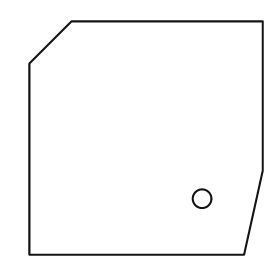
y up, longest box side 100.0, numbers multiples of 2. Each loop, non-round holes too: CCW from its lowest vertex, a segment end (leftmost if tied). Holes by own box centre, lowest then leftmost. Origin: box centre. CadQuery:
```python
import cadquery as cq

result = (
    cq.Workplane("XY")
    .moveTo(-50.0, -50.0)
    .lineTo(42.0, -50.0)
    .lineTo(50.0, -14.0)
    .lineTo(50.0, 50.0)
    .lineTo(-32.0, 50.0)
    .lineTo(-50.0, 32.0)
    .close()
    .moveTo(24.0, -26.0)
    .circle(4.0)
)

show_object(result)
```